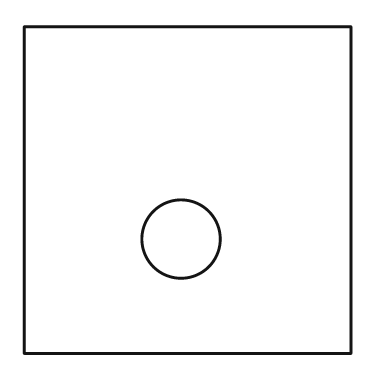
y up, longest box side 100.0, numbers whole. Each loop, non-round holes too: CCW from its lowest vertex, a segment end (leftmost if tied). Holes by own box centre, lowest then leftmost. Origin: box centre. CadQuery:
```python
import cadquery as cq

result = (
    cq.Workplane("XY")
    .moveTo(-50.0, -50.0)
    .lineTo(50.0, -50.0)
    .lineTo(50.0, 50.0)
    .lineTo(-50.0, 50.0)
    .close()
    .moveTo(-2.0, -15.0)
    .circle(12.0)
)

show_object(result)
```